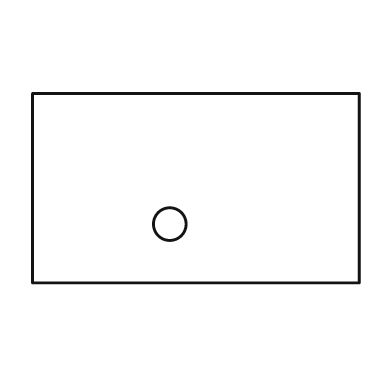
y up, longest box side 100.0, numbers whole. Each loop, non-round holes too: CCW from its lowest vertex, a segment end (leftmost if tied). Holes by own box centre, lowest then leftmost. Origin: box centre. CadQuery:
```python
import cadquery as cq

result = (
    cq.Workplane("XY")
    .moveTo(-50.0, -29.0)
    .lineTo(50.0, -29.0)
    .lineTo(50.0, 29.0)
    .lineTo(-50.0, 29.0)
    .close()
    .moveTo(-8.0, -11.0)
    .circle(5.0)
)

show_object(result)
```